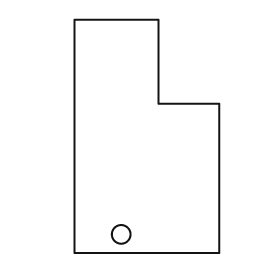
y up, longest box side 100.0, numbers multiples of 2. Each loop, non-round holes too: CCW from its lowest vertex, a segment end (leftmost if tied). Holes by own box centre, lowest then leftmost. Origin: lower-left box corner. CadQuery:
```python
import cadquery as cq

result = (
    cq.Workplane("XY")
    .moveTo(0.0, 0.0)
    .lineTo(62.0, 0.0)
    .lineTo(62.0, 64.0)
    .lineTo(36.0, 64.0)
    .lineTo(36.0, 100.0)
    .lineTo(0.0, 100.0)
    .close()
    .moveTo(20.0, 8.0)
    .circle(4.0)
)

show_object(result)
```